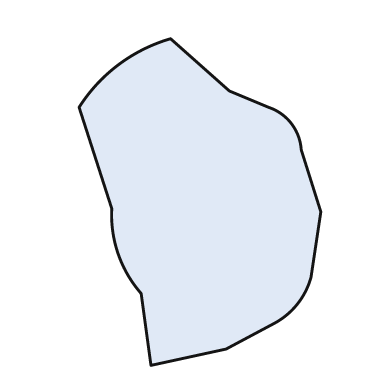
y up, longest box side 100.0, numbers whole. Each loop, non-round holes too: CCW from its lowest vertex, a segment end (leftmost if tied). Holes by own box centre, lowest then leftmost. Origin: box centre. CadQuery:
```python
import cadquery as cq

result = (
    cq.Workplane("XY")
    .moveTo(-15.0, -50.0)
    .lineTo(8.0, -45.0)
    .lineTo(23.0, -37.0)
    .threePointArc((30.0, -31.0), (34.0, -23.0))
    .lineTo(37.0, -3.0)
    .lineTo(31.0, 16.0)
    .threePointArc((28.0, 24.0), (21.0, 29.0))
    .lineTo(9.0, 34.0)
    .lineTo(-9.0, 50.0)
    .threePointArc((-25.0, 42.0), (-37.0, 29.0))
    .lineTo(-27.0, -2.0)
    .threePointArc((-25.0, -16.0), (-18.0, -28.0))
    .close()
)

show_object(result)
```